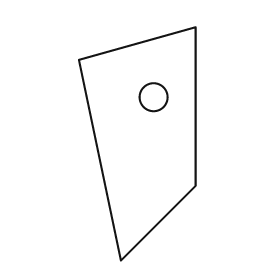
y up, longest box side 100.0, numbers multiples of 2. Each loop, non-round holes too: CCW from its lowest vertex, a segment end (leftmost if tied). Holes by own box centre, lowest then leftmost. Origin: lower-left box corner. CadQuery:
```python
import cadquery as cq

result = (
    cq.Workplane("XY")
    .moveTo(18.0, 0.0)
    .lineTo(50.0, 32.0)
    .lineTo(50.0, 100.0)
    .lineTo(0.0, 86.0)
    .close()
    .moveTo(32.0, 70.0)
    .circle(6.0)
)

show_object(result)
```